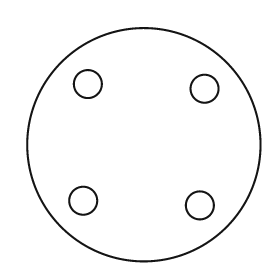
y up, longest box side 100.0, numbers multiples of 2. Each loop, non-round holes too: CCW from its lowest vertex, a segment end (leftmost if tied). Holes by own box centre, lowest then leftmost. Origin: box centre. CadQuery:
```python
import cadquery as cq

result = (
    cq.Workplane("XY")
    .moveTo(0.0, 0.0)
    .circle(50.0)
    .moveTo(24.0, -26.0)
    .circle(6.0)
    .moveTo(-26.0, -24.0)
    .circle(6.0)
    .moveTo(26.0, 24.0)
    .circle(6.0)
    .moveTo(-24.0, 26.0)
    .circle(6.0)
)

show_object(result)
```